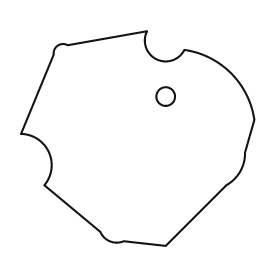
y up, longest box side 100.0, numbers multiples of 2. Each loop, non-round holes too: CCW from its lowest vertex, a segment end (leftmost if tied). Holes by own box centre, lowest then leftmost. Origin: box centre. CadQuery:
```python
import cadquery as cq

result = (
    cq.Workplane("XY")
    .moveTo(12.0, -46.0)
    .lineTo(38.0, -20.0)
    .threePointArc((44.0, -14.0), (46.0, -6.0))
    .lineTo(50.0, 8.0)
    .threePointArc((40.0, 28.0), (20.0, 38.0))
    .threePointArc((8.0, 34.0), (4.0, 46.0))
    .lineTo(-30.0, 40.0)
    .threePointArc((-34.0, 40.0), (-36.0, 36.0))
    .lineTo(-50.0, 2.0)
    .threePointArc((-38.0, -6.0), (-40.0, -20.0))
    .lineTo(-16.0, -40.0)
    .threePointArc((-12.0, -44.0), (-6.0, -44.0))
    .close()
    .moveTo(12.0, 18.0)
    .circle(4.0)
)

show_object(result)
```